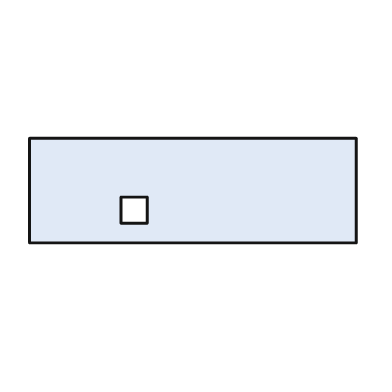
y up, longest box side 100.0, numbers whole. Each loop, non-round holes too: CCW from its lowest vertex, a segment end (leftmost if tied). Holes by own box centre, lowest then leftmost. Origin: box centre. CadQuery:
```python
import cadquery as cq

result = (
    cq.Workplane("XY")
    .moveTo(-50.0, -16.0)
    .lineTo(50.0, -16.0)
    .lineTo(50.0, 16.0)
    .lineTo(-50.0, 16.0)
    .close()
    .moveTo(-22.0, -10.0)
    .lineTo(-14.0, -10.0)
    .lineTo(-14.0, -2.0)
    .lineTo(-22.0, -2.0)
    .close()
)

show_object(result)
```